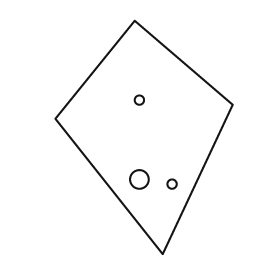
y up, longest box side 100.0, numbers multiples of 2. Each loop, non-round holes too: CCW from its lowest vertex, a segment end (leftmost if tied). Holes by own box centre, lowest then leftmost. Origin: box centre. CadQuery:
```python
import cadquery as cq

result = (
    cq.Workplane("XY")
    .moveTo(8.0, -50.0)
    .lineTo(38.0, 14.0)
    .lineTo(-4.0, 50.0)
    .lineTo(-38.0, 8.0)
    .close()
    .moveTo(12.0, -20.0)
    .circle(2.0)
    .moveTo(-2.0, -18.0)
    .circle(4.0)
    .moveTo(-2.0, 16.0)
    .circle(2.0)
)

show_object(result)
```